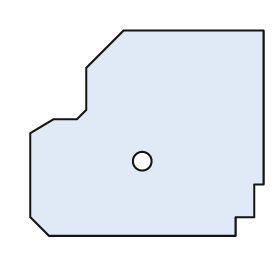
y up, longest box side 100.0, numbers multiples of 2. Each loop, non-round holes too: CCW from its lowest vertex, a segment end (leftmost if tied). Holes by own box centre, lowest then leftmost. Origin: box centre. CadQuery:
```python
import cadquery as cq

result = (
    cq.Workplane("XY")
    .moveTo(-42.0, -44.0)
    .lineTo(38.0, -44.0)
    .lineTo(38.0, -36.0)
    .lineTo(46.0, -36.0)
    .lineTo(46.0, -22.0)
    .lineTo(50.0, -22.0)
    .lineTo(50.0, 44.0)
    .lineTo(-10.0, 44.0)
    .lineTo(-26.0, 28.0)
    .lineTo(-26.0, 10.0)
    .lineTo(-30.0, 6.0)
    .lineTo(-40.0, 6.0)
    .lineTo(-50.0, 0.0)
    .lineTo(-50.0, -36.0)
    .close()
    .moveTo(-2.0, -12.0)
    .circle(4.0)
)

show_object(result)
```